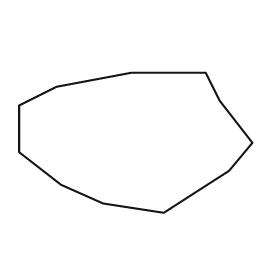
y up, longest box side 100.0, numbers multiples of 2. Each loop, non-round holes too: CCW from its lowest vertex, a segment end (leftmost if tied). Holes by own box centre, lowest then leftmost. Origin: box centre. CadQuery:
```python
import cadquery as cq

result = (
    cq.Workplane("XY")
    .moveTo(12.0, -30.0)
    .lineTo(40.0, -12.0)
    .lineTo(50.0, 0.0)
    .lineTo(36.0, 18.0)
    .lineTo(30.0, 30.0)
    .lineTo(-2.0, 30.0)
    .lineTo(-34.0, 24.0)
    .lineTo(-50.0, 16.0)
    .lineTo(-50.0, -4.0)
    .lineTo(-32.0, -18.0)
    .lineTo(-14.0, -26.0)
    .close()
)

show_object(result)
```